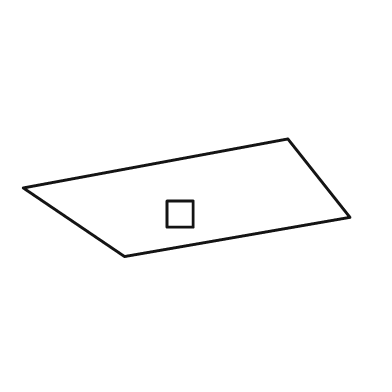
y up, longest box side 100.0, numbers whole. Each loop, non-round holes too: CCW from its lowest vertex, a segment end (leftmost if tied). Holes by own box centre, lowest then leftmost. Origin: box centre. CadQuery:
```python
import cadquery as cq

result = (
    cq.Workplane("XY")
    .moveTo(-19.0, -18.0)
    .lineTo(50.0, -6.0)
    .lineTo(31.0, 18.0)
    .lineTo(-50.0, 3.0)
    .close()
    .moveTo(-6.0, -9.0)
    .lineTo(2.0, -9.0)
    .lineTo(2.0, -1.0)
    .lineTo(-6.0, -1.0)
    .close()
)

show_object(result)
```